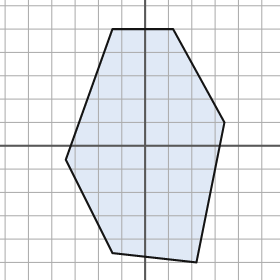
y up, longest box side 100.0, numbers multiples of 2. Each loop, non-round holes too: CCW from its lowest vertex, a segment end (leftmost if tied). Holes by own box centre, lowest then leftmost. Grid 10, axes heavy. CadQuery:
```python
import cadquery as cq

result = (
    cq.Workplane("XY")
    .moveTo(22.0, -50.0)
    .lineTo(34.0, 10.0)
    .lineTo(12.0, 50.0)
    .lineTo(-14.0, 50.0)
    .lineTo(-34.0, -6.0)
    .lineTo(-14.0, -46.0)
    .close()
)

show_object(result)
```